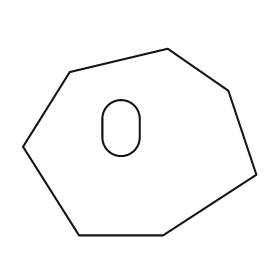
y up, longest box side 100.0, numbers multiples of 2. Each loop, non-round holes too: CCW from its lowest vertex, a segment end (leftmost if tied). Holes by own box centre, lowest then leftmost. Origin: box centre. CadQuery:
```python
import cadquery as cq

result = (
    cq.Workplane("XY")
    .moveTo(-26.0, -40.0)
    .lineTo(10.0, -40.0)
    .lineTo(50.0, -14.0)
    .lineTo(38.0, 22.0)
    .lineTo(12.0, 40.0)
    .lineTo(-30.0, 30.0)
    .lineTo(-50.0, -2.0)
    .close()
    .moveTo(-16.0, 2.0)
    .threePointArc((-8.0, -6.0), (0.0, 2.0))
    .lineTo(0.0, 10.0)
    .threePointArc((-8.0, 18.0), (-16.0, 10.0))
    .close()
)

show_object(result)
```